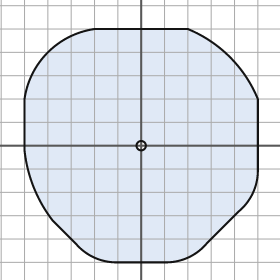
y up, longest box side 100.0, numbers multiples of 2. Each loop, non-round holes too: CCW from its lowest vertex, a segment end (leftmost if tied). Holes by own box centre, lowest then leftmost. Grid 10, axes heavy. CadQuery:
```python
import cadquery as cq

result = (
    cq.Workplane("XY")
    .moveTo(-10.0, -50.0)
    .lineTo(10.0, -50.0)
    .threePointArc((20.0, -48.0), (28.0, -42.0))
    .lineTo(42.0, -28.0)
    .threePointArc((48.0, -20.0), (50.0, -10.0))
    .lineTo(50.0, 20.0)
    .threePointArc((38.0, 38.0), (20.0, 50.0))
    .lineTo(-20.0, 50.0)
    .threePointArc((-40.0, 40.0), (-50.0, 20.0))
    .lineTo(-50.0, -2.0)
    .threePointArc((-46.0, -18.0), (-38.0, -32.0))
    .lineTo(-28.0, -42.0)
    .threePointArc((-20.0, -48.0), (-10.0, -50.0))
    .close()
    .moveTo(0.0, 0.0)
    .circle(2.0)
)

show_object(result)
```